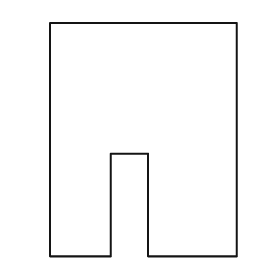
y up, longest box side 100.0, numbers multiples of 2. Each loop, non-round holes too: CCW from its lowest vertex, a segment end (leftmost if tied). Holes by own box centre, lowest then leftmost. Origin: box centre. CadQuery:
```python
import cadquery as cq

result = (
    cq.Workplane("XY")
    .moveTo(-40.0, -50.0)
    .lineTo(-14.0, -50.0)
    .lineTo(-14.0, -6.0)
    .lineTo(2.0, -6.0)
    .lineTo(2.0, -50.0)
    .lineTo(40.0, -50.0)
    .lineTo(40.0, 50.0)
    .lineTo(-40.0, 50.0)
    .close()
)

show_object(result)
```